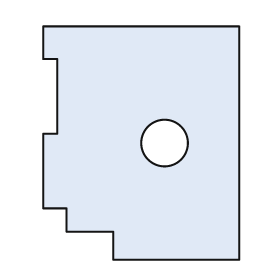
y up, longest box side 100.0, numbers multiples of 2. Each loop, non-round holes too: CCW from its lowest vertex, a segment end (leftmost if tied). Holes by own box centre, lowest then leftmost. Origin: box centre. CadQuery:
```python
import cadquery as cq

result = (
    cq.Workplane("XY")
    .moveTo(-12.0, -50.0)
    .lineTo(42.0, -50.0)
    .lineTo(42.0, 50.0)
    .lineTo(-42.0, 50.0)
    .lineTo(-42.0, 36.0)
    .lineTo(-36.0, 36.0)
    .lineTo(-36.0, 4.0)
    .lineTo(-42.0, 4.0)
    .lineTo(-42.0, -28.0)
    .lineTo(-32.0, -28.0)
    .lineTo(-32.0, -38.0)
    .lineTo(-12.0, -38.0)
    .close()
    .moveTo(10.0, 0.0)
    .circle(10.0)
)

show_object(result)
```